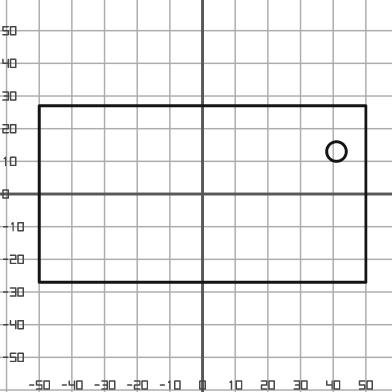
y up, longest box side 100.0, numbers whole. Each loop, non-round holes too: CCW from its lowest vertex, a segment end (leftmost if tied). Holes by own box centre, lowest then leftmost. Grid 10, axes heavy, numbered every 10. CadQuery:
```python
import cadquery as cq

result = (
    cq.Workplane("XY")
    .moveTo(-50.0, -27.0)
    .lineTo(50.0, -27.0)
    .lineTo(50.0, 27.0)
    .lineTo(-50.0, 27.0)
    .close()
    .moveTo(41.0, 13.0)
    .circle(3.0)
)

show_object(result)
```